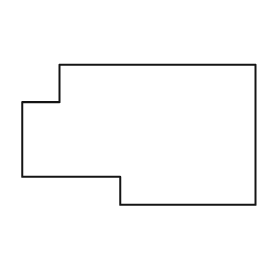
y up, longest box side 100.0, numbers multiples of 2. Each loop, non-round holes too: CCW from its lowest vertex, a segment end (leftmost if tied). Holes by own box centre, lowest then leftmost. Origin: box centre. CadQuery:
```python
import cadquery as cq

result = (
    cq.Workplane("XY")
    .moveTo(-8.0, -30.0)
    .lineTo(50.0, -30.0)
    .lineTo(50.0, 30.0)
    .lineTo(-34.0, 30.0)
    .lineTo(-34.0, 14.0)
    .lineTo(-50.0, 14.0)
    .lineTo(-50.0, -18.0)
    .lineTo(-8.0, -18.0)
    .close()
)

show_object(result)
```